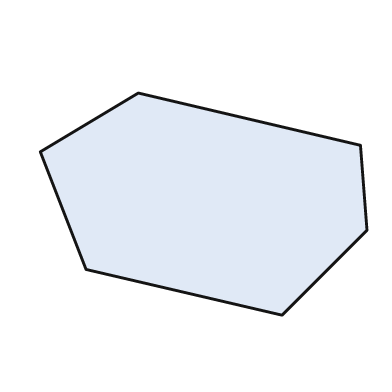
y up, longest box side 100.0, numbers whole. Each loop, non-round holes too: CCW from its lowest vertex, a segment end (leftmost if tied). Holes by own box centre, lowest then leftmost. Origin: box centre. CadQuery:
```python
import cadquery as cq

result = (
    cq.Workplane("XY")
    .moveTo(24.0, -34.0)
    .lineTo(50.0, -8.0)
    .lineTo(48.0, 18.0)
    .lineTo(-20.0, 34.0)
    .lineTo(-50.0, 16.0)
    .lineTo(-36.0, -20.0)
    .close()
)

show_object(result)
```